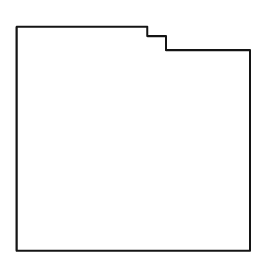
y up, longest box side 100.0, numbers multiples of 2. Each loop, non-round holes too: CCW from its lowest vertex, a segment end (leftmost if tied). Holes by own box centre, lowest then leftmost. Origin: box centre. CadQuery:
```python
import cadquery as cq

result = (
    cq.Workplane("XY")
    .moveTo(-50.0, -48.0)
    .lineTo(50.0, -48.0)
    .lineTo(50.0, 38.0)
    .lineTo(14.0, 38.0)
    .lineTo(14.0, 44.0)
    .lineTo(6.0, 44.0)
    .lineTo(6.0, 48.0)
    .lineTo(-50.0, 48.0)
    .close()
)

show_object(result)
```